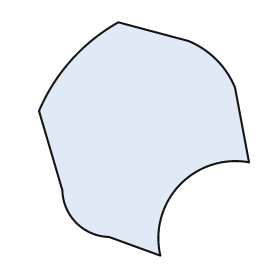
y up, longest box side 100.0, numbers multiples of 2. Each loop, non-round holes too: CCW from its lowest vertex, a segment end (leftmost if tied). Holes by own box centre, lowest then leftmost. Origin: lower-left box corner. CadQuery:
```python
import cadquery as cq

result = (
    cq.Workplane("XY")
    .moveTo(52.0, 0.0)
    .threePointArc((60.0, 30.0), (90.0, 40.0))
    .lineTo(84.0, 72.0)
    .threePointArc((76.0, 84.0), (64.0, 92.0))
    .lineTo(34.0, 100.0)
    .threePointArc((14.0, 84.0), (0.0, 62.0))
    .lineTo(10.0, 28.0)
    .threePointArc((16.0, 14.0), (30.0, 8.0))
    .close()
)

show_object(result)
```